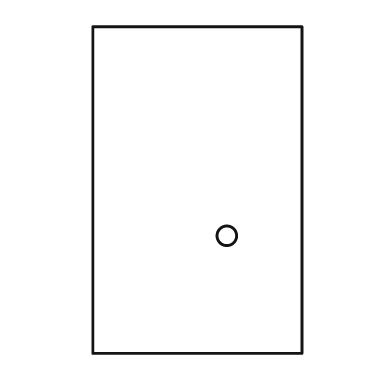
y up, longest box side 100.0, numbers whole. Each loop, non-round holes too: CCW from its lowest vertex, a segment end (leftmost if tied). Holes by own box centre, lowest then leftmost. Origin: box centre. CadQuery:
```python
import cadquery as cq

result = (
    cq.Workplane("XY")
    .moveTo(-32.0, -50.0)
    .lineTo(32.0, -50.0)
    .lineTo(32.0, 50.0)
    .lineTo(-32.0, 50.0)
    .close()
    .moveTo(9.0, -14.0)
    .circle(3.0)
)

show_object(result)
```